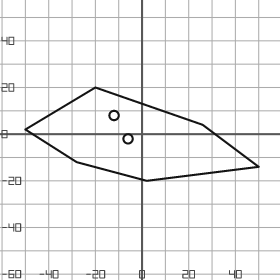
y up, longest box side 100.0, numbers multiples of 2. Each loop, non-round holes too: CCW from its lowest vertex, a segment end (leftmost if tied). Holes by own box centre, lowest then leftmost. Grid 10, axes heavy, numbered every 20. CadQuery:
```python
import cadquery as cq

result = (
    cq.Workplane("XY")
    .moveTo(2.0, -20.0)
    .lineTo(50.0, -14.0)
    .lineTo(26.0, 4.0)
    .lineTo(-20.0, 20.0)
    .lineTo(-50.0, 2.0)
    .lineTo(-28.0, -12.0)
    .close()
    .moveTo(-6.0, -2.0)
    .circle(2.0)
    .moveTo(-12.0, 8.0)
    .circle(2.0)
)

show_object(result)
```